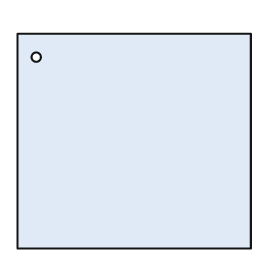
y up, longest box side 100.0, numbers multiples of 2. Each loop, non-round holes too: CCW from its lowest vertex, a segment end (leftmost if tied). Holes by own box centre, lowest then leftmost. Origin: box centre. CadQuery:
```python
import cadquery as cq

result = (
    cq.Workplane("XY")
    .moveTo(-50.0, -46.0)
    .lineTo(50.0, -46.0)
    .lineTo(50.0, 46.0)
    .lineTo(-50.0, 46.0)
    .close()
    .moveTo(-42.0, 36.0)
    .circle(2.0)
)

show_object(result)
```